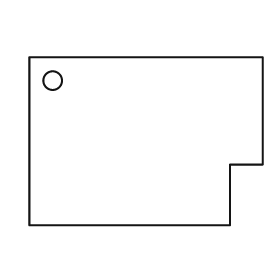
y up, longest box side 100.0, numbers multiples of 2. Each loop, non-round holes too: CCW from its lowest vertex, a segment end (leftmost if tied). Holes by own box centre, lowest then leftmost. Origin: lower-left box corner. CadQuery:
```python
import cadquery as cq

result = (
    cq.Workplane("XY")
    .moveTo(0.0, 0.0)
    .lineTo(86.0, 0.0)
    .lineTo(86.0, 26.0)
    .lineTo(100.0, 26.0)
    .lineTo(100.0, 72.0)
    .lineTo(0.0, 72.0)
    .close()
    .moveTo(10.0, 62.0)
    .circle(4.0)
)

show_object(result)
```